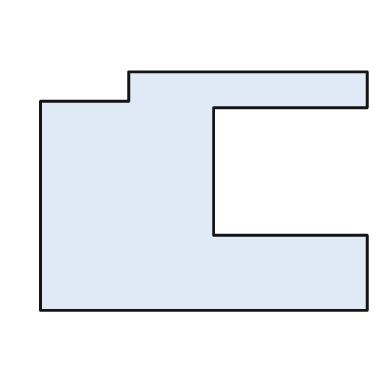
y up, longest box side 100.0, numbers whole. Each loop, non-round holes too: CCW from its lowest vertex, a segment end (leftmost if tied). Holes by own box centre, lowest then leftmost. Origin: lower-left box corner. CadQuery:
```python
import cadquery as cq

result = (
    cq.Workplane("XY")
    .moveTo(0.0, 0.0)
    .lineTo(100.0, 0.0)
    .lineTo(100.0, 23.0)
    .lineTo(53.0, 23.0)
    .lineTo(53.0, 62.0)
    .lineTo(100.0, 62.0)
    .lineTo(100.0, 73.0)
    .lineTo(27.0, 73.0)
    .lineTo(27.0, 64.0)
    .lineTo(0.0, 64.0)
    .close()
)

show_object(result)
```